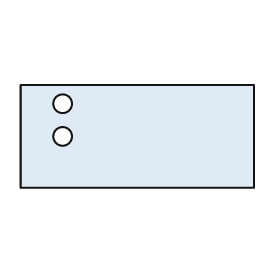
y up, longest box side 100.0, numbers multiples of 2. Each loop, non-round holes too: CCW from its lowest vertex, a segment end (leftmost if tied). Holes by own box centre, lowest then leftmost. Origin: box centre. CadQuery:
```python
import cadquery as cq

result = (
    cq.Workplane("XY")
    .moveTo(-50.0, -22.0)
    .lineTo(50.0, -22.0)
    .lineTo(50.0, 22.0)
    .lineTo(-50.0, 22.0)
    .close()
    .moveTo(-32.0, 0.0)
    .circle(4.0)
    .moveTo(-32.0, 14.0)
    .circle(4.0)
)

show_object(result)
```